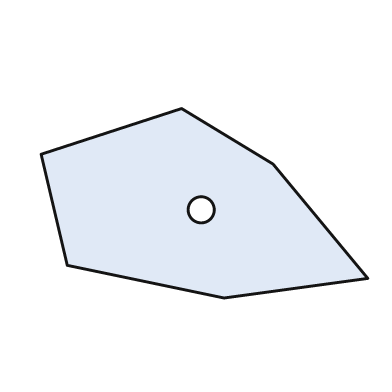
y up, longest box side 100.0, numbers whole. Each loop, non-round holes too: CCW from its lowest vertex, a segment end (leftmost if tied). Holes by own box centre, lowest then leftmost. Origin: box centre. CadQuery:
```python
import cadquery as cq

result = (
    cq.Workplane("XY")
    .moveTo(6.0, -29.0)
    .lineTo(50.0, -23.0)
    .lineTo(21.0, 12.0)
    .lineTo(-7.0, 29.0)
    .lineTo(-50.0, 15.0)
    .lineTo(-42.0, -19.0)
    .close()
    .moveTo(-1.0, -2.0)
    .circle(4.0)
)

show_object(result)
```